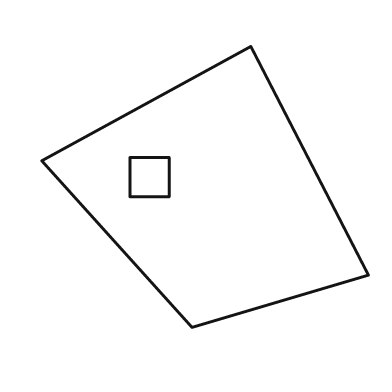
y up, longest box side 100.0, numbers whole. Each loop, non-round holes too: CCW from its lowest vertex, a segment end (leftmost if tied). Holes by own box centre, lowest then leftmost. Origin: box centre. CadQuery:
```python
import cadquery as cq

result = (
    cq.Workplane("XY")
    .moveTo(-4.0, -43.0)
    .lineTo(50.0, -27.0)
    .lineTo(14.0, 43.0)
    .lineTo(-50.0, 8.0)
    .close()
    .moveTo(-23.0, -3.0)
    .lineTo(-11.0, -3.0)
    .lineTo(-11.0, 9.0)
    .lineTo(-23.0, 9.0)
    .close()
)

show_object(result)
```